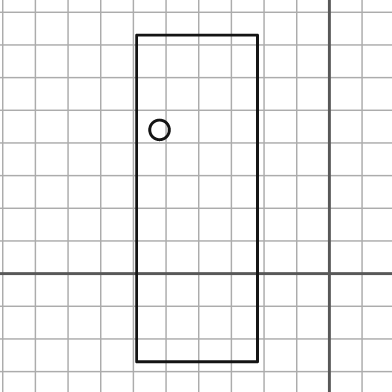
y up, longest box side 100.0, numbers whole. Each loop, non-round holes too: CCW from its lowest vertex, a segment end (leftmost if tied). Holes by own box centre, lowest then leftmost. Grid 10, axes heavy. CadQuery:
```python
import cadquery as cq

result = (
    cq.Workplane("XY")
    .moveTo(-59.0, -27.0)
    .lineTo(-22.0, -27.0)
    .lineTo(-22.0, 73.0)
    .lineTo(-59.0, 73.0)
    .close()
    .moveTo(-52.0, 44.0)
    .circle(3.0)
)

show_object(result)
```